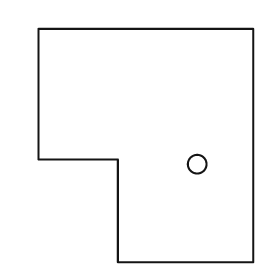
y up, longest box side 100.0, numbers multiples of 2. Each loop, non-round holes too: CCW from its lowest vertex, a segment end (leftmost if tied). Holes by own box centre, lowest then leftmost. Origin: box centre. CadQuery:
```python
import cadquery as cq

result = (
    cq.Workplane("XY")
    .moveTo(-12.0, -50.0)
    .lineTo(46.0, -50.0)
    .lineTo(46.0, 50.0)
    .lineTo(-46.0, 50.0)
    .lineTo(-46.0, -6.0)
    .lineTo(-12.0, -6.0)
    .close()
    .moveTo(22.0, -8.0)
    .circle(4.0)
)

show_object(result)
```